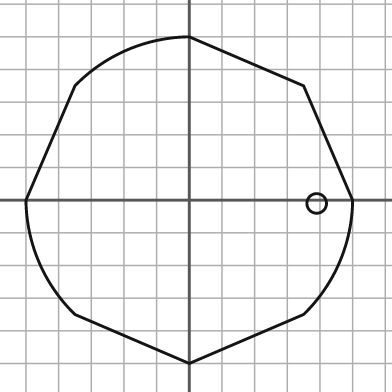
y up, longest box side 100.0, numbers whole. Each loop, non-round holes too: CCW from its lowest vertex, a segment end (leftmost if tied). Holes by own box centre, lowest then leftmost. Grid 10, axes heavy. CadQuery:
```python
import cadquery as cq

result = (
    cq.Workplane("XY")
    .moveTo(0.0, -50.0)
    .lineTo(35.0, -35.0)
    .threePointArc((46.0, -19.0), (50.0, 0.0))
    .lineTo(35.0, 35.0)
    .lineTo(0.0, 50.0)
    .threePointArc((-19.0, 46.0), (-35.0, 35.0))
    .lineTo(-50.0, 0.0)
    .threePointArc((-46.0, -19.0), (-35.0, -35.0))
    .close()
    .moveTo(39.0, -1.0)
    .circle(3.0)
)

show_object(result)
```